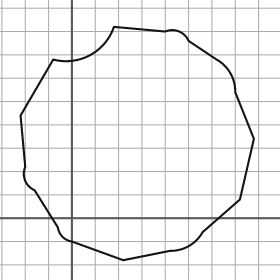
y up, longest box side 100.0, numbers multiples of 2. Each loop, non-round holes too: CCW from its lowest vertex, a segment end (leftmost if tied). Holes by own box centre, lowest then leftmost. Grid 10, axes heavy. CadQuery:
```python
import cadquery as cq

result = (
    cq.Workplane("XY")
    .moveTo(22.0, -18.0)
    .lineTo(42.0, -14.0)
    .threePointArc((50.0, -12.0), (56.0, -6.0))
    .lineTo(72.0, 8.0)
    .lineTo(78.0, 34.0)
    .lineTo(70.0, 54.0)
    .threePointArc((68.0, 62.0), (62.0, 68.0))
    .lineTo(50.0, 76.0)
    .threePointArc((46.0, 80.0), (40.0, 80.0))
    .lineTo(18.0, 82.0)
    .threePointArc((8.0, 70.0), (-8.0, 68.0))
    .lineTo(-22.0, 44.0)
    .lineTo(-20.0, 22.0)
    .threePointArc((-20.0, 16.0), (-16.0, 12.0))
    .lineTo(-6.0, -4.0)
    .threePointArc((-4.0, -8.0), (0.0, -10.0))
    .close()
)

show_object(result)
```